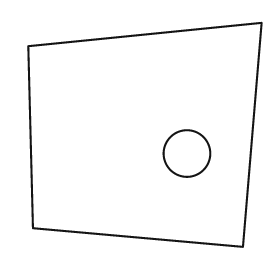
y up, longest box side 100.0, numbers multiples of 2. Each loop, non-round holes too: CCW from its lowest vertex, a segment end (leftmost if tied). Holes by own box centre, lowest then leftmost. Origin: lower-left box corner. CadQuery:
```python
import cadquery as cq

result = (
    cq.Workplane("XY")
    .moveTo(92.0, 0.0)
    .lineTo(100.0, 96.0)
    .lineTo(0.0, 86.0)
    .lineTo(2.0, 8.0)
    .close()
    .moveTo(68.0, 40.0)
    .circle(10.0)
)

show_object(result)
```